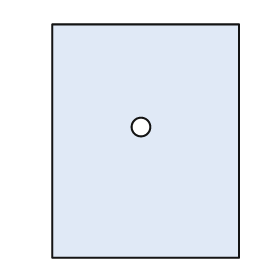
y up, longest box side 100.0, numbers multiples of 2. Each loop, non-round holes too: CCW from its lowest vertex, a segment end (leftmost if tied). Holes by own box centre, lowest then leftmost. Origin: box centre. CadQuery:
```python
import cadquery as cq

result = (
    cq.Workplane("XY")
    .moveTo(-40.0, -50.0)
    .lineTo(40.0, -50.0)
    .lineTo(40.0, 50.0)
    .lineTo(-40.0, 50.0)
    .close()
    .moveTo(-2.0, 6.0)
    .circle(4.0)
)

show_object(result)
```